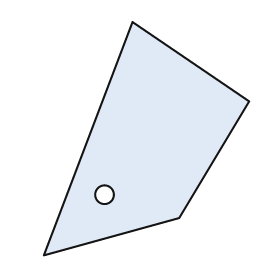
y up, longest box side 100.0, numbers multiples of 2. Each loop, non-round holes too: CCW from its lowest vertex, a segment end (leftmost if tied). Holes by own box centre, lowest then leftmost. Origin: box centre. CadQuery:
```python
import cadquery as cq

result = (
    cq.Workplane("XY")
    .moveTo(-44.0, -50.0)
    .lineTo(14.0, -34.0)
    .lineTo(44.0, 16.0)
    .lineTo(-6.0, 50.0)
    .close()
    .moveTo(-18.0, -24.0)
    .circle(4.0)
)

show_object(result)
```